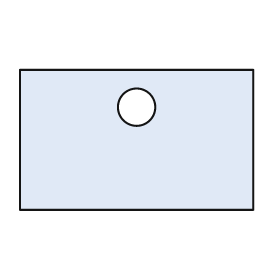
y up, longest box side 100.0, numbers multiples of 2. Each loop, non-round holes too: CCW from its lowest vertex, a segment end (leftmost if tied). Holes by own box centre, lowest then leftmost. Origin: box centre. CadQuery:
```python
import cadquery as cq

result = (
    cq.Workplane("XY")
    .moveTo(-50.0, -30.0)
    .lineTo(50.0, -30.0)
    .lineTo(50.0, 30.0)
    .lineTo(-50.0, 30.0)
    .close()
    .moveTo(0.0, 14.0)
    .circle(8.0)
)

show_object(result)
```